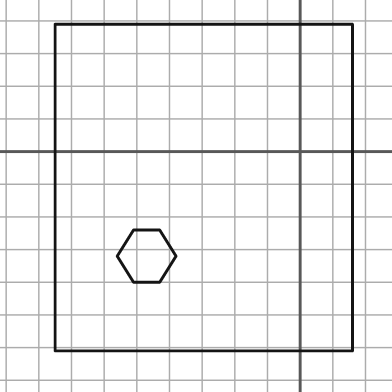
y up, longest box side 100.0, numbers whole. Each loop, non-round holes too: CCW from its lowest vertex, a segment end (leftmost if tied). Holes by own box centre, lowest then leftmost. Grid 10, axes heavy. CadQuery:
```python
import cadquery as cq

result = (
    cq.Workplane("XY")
    .moveTo(-75.0, -61.0)
    .lineTo(16.0, -61.0)
    .lineTo(16.0, 39.0)
    .lineTo(-75.0, 39.0)
    .close()
    .moveTo(-51.0, -40.0)
    .lineTo(-43.0, -40.0)
    .lineTo(-38.0, -32.0)
    .lineTo(-43.0, -24.0)
    .lineTo(-51.0, -24.0)
    .lineTo(-56.0, -32.0)
    .close()
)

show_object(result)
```